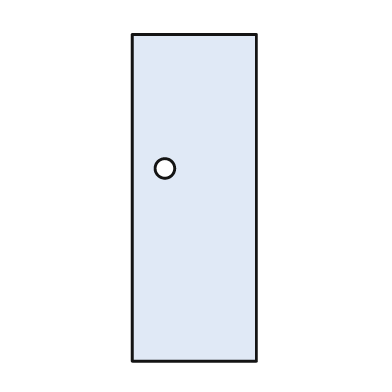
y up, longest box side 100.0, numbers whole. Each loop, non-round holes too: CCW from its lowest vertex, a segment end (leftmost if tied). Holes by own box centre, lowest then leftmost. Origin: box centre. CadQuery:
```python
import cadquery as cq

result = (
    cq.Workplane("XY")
    .moveTo(-19.0, -50.0)
    .lineTo(19.0, -50.0)
    .lineTo(19.0, 50.0)
    .lineTo(-19.0, 50.0)
    .close()
    .moveTo(-9.0, 9.0)
    .circle(3.0)
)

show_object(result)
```